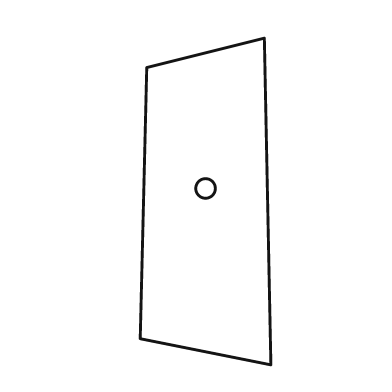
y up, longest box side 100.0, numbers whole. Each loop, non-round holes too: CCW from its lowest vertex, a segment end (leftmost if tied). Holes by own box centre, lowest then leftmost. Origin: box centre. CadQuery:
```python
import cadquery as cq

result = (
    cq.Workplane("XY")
    .moveTo(20.0, -50.0)
    .lineTo(18.0, 50.0)
    .lineTo(-18.0, 41.0)
    .lineTo(-20.0, -42.0)
    .close()
    .moveTo(0.0, 4.0)
    .circle(3.0)
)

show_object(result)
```